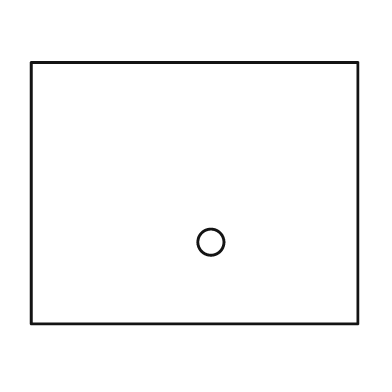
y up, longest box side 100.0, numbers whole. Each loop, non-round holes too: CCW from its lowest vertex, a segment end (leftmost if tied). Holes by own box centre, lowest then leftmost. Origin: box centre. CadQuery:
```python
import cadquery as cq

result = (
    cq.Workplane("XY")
    .moveTo(-50.0, -40.0)
    .lineTo(50.0, -40.0)
    .lineTo(50.0, 40.0)
    .lineTo(-50.0, 40.0)
    .close()
    .moveTo(5.0, -15.0)
    .circle(4.0)
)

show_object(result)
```